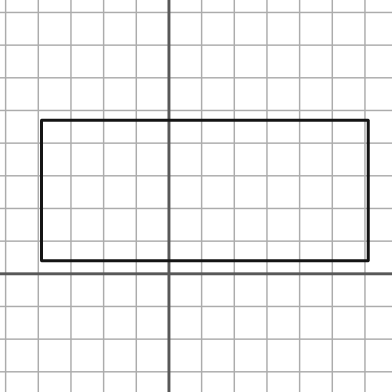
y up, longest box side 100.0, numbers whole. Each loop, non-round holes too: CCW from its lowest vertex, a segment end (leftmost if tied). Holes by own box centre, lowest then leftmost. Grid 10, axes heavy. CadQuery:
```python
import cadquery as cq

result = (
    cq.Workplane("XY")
    .moveTo(-39.0, 4.0)
    .lineTo(61.0, 4.0)
    .lineTo(61.0, 47.0)
    .lineTo(-39.0, 47.0)
    .close()
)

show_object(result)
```